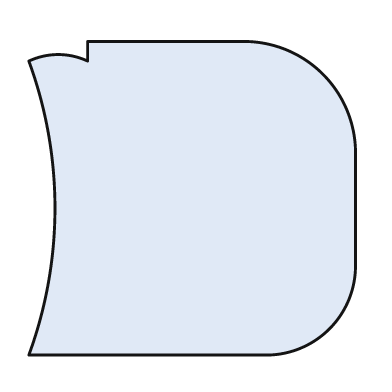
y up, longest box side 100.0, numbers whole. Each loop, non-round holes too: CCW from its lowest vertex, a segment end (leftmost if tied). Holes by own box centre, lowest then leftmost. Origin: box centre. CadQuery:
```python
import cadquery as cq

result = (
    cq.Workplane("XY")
    .moveTo(-50.0, -48.0)
    .lineTo(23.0, -48.0)
    .threePointArc((42.0, -40.0), (50.0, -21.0))
    .lineTo(50.0, 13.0)
    .threePointArc((40.0, 38.0), (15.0, 48.0))
    .lineTo(-32.0, 48.0)
    .lineTo(-32.0, 42.0)
    .threePointArc((-41.0, 44.0), (-50.0, 42.0))
    .threePointArc((-42.0, -3.0), (-50.0, -48.0))
    .close()
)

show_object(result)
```